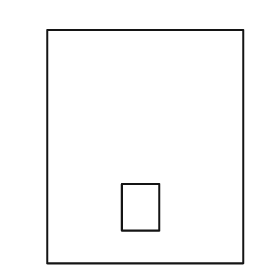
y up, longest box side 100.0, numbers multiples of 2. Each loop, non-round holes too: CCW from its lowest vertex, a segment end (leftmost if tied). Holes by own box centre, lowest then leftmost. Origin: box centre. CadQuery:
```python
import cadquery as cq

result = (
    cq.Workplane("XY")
    .moveTo(-42.0, -50.0)
    .lineTo(42.0, -50.0)
    .lineTo(42.0, 50.0)
    .lineTo(-42.0, 50.0)
    .close()
    .moveTo(-10.0, -36.0)
    .lineTo(6.0, -36.0)
    .lineTo(6.0, -16.0)
    .lineTo(-10.0, -16.0)
    .close()
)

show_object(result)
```